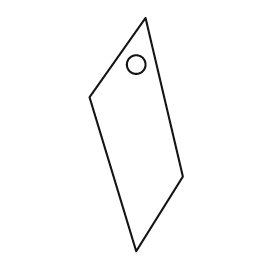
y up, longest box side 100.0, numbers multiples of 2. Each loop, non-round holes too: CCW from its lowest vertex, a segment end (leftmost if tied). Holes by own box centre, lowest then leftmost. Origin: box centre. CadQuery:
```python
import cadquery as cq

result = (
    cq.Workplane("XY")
    .moveTo(0.0, -50.0)
    .lineTo(20.0, -18.0)
    .lineTo(4.0, 50.0)
    .lineTo(-20.0, 16.0)
    .close()
    .moveTo(0.0, 30.0)
    .circle(4.0)
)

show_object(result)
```